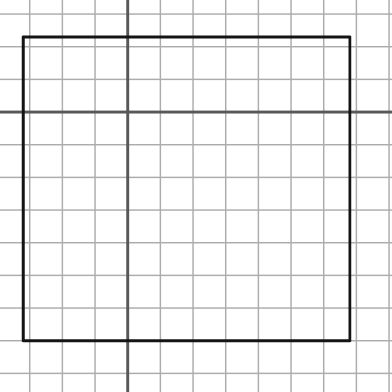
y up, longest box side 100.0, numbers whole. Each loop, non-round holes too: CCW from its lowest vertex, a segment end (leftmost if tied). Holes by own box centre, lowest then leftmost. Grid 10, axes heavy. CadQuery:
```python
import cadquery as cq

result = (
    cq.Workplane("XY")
    .moveTo(-32.0, -70.0)
    .lineTo(68.0, -70.0)
    .lineTo(68.0, 23.0)
    .lineTo(-32.0, 23.0)
    .close()
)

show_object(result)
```